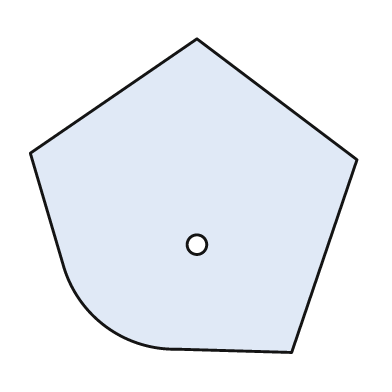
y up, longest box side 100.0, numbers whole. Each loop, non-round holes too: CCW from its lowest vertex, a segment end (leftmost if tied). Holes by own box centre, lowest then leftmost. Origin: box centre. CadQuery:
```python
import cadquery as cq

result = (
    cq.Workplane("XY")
    .moveTo(30.0, -48.0)
    .lineTo(50.0, 11.0)
    .lineTo(1.0, 48.0)
    .lineTo(-50.0, 13.0)
    .lineTo(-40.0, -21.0)
    .threePointArc((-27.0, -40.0), (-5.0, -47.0))
    .close()
    .moveTo(1.0, -15.0)
    .circle(3.0)
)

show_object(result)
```